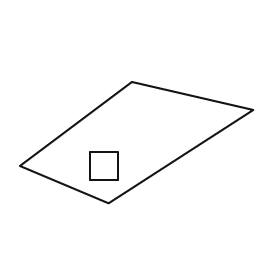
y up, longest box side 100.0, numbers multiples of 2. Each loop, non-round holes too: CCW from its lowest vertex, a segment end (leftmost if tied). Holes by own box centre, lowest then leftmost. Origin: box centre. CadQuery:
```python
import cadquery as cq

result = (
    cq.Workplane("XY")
    .moveTo(-12.0, -26.0)
    .lineTo(50.0, 14.0)
    .lineTo(-2.0, 26.0)
    .lineTo(-50.0, -10.0)
    .close()
    .moveTo(-20.0, -16.0)
    .lineTo(-8.0, -16.0)
    .lineTo(-8.0, -4.0)
    .lineTo(-20.0, -4.0)
    .close()
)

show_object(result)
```